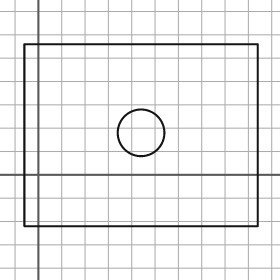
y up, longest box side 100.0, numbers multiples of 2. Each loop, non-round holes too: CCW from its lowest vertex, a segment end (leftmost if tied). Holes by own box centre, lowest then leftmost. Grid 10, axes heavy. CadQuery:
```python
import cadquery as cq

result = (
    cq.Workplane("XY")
    .moveTo(-6.0, -22.0)
    .lineTo(94.0, -22.0)
    .lineTo(94.0, 56.0)
    .lineTo(-6.0, 56.0)
    .close()
    .moveTo(44.0, 18.0)
    .circle(10.0)
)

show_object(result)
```